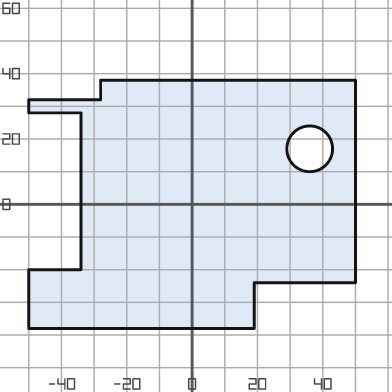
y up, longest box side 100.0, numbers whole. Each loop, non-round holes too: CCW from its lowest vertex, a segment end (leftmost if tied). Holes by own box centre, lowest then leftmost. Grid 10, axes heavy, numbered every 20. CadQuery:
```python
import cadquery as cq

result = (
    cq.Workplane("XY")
    .moveTo(-50.0, -38.0)
    .lineTo(19.0, -38.0)
    .lineTo(19.0, -24.0)
    .lineTo(50.0, -24.0)
    .lineTo(50.0, 38.0)
    .lineTo(-28.0, 38.0)
    .lineTo(-28.0, 32.0)
    .lineTo(-50.0, 32.0)
    .lineTo(-50.0, 28.0)
    .lineTo(-34.0, 28.0)
    .lineTo(-34.0, -20.0)
    .lineTo(-50.0, -20.0)
    .close()
    .moveTo(36.0, 17.0)
    .circle(7.0)
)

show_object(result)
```